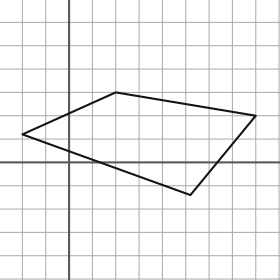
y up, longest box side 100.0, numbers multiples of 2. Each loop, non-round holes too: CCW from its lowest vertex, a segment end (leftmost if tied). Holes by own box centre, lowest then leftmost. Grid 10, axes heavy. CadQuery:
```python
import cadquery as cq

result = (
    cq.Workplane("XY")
    .moveTo(52.0, -14.0)
    .lineTo(80.0, 20.0)
    .lineTo(20.0, 30.0)
    .lineTo(-20.0, 12.0)
    .close()
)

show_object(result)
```